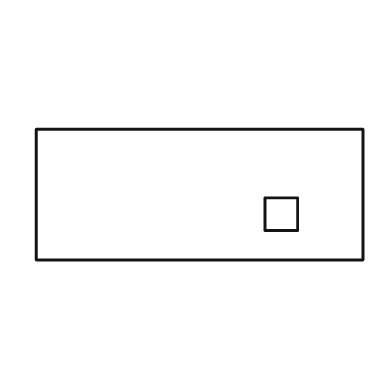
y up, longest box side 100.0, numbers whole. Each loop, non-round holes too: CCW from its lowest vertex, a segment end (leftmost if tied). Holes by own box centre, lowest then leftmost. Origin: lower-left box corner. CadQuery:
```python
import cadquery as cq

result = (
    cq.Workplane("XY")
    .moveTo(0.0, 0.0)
    .lineTo(100.0, 0.0)
    .lineTo(100.0, 40.0)
    .lineTo(0.0, 40.0)
    .close()
    .moveTo(70.0, 9.0)
    .lineTo(80.0, 9.0)
    .lineTo(80.0, 19.0)
    .lineTo(70.0, 19.0)
    .close()
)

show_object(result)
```